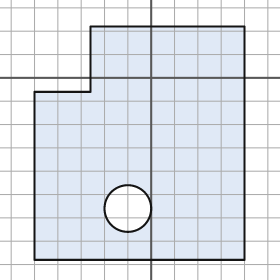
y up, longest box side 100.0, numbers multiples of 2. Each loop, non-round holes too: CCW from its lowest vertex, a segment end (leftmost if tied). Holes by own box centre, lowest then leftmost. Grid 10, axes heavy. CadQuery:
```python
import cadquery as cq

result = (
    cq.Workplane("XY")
    .moveTo(-50.0, -78.0)
    .lineTo(40.0, -78.0)
    .lineTo(40.0, 22.0)
    .lineTo(-26.0, 22.0)
    .lineTo(-26.0, -6.0)
    .lineTo(-50.0, -6.0)
    .close()
    .moveTo(-10.0, -56.0)
    .circle(10.0)
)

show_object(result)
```